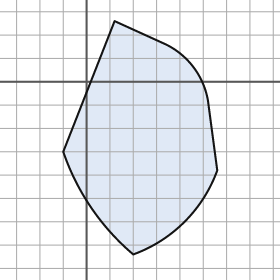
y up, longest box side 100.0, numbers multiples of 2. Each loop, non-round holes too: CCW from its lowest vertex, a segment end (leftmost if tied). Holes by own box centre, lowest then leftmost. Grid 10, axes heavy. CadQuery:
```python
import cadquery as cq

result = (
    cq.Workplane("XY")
    .moveTo(20.0, -74.0)
    .threePointArc((42.0, -60.0), (56.0, -38.0))
    .lineTo(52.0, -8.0)
    .threePointArc((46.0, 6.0), (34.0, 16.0))
    .lineTo(12.0, 26.0)
    .lineTo(-10.0, -30.0)
    .threePointArc((2.0, -54.0), (20.0, -74.0))
    .close()
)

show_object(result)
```